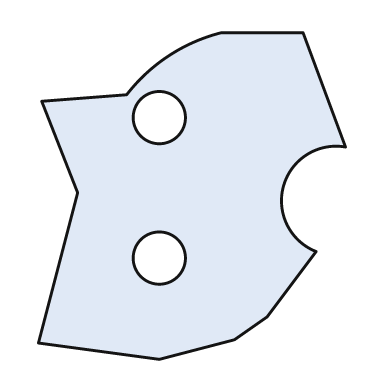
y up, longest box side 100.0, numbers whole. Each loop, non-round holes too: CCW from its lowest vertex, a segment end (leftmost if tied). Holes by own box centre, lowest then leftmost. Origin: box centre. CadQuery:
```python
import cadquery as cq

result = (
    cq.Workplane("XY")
    .moveTo(-10.0, -50.0)
    .lineTo(13.0, -44.0)
    .lineTo(23.0, -37.0)
    .lineTo(38.0, -17.0)
    .threePointArc((28.0, 3.0), (47.0, 15.0))
    .lineTo(34.0, 50.0)
    .lineTo(9.0, 50.0)
    .threePointArc((-7.0, 43.0), (-20.0, 31.0))
    .lineTo(-46.0, 29.0)
    .lineTo(-35.0, 1.0)
    .lineTo(-47.0, -45.0)
    .close()
    .moveTo(-10.0, -19.0)
    .circle(8.0)
    .moveTo(-10.0, 24.0)
    .circle(8.0)
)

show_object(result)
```